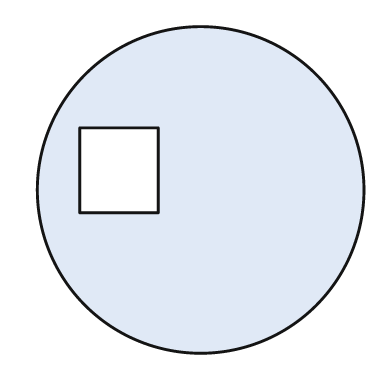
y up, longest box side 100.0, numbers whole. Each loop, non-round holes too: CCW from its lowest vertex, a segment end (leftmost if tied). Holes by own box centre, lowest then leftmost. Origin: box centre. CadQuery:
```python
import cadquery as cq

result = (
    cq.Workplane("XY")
    .moveTo(0.0, 0.0)
    .circle(50.0)
    .moveTo(-37.0, -7.0)
    .lineTo(-13.0, -7.0)
    .lineTo(-13.0, 19.0)
    .lineTo(-37.0, 19.0)
    .close()
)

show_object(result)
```